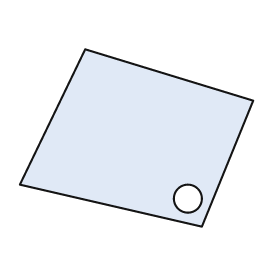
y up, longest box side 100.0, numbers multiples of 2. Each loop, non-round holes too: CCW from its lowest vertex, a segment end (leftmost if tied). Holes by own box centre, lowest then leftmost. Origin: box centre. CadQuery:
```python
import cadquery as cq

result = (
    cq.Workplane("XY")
    .moveTo(28.0, -38.0)
    .lineTo(50.0, 16.0)
    .lineTo(-22.0, 38.0)
    .lineTo(-50.0, -20.0)
    .close()
    .moveTo(22.0, -26.0)
    .circle(6.0)
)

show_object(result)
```